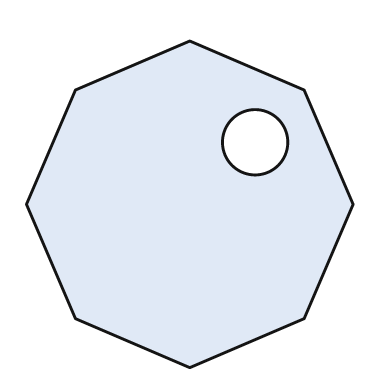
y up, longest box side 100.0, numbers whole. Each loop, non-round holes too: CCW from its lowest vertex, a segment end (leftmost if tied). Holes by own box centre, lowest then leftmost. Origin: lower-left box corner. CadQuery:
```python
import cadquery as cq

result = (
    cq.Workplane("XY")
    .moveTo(50.0, 0.0)
    .lineTo(85.0, 15.0)
    .lineTo(100.0, 50.0)
    .lineTo(85.0, 85.0)
    .lineTo(50.0, 100.0)
    .lineTo(15.0, 85.0)
    .lineTo(0.0, 50.0)
    .lineTo(15.0, 15.0)
    .close()
    .moveTo(70.0, 69.0)
    .circle(10.0)
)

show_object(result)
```